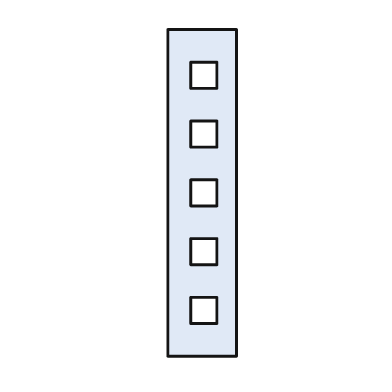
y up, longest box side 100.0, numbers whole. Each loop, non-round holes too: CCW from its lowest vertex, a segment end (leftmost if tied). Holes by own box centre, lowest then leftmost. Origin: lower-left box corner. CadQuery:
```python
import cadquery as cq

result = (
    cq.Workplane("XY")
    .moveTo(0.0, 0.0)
    .lineTo(21.0, 0.0)
    .lineTo(21.0, 100.0)
    .lineTo(0.0, 100.0)
    .close()
    .moveTo(7.0, 10.0)
    .lineTo(15.0, 10.0)
    .lineTo(15.0, 18.0)
    .lineTo(7.0, 18.0)
    .close()
    .moveTo(7.0, 28.0)
    .lineTo(15.0, 28.0)
    .lineTo(15.0, 36.0)
    .lineTo(7.0, 36.0)
    .close()
    .moveTo(7.0, 46.0)
    .lineTo(15.0, 46.0)
    .lineTo(15.0, 54.0)
    .lineTo(7.0, 54.0)
    .close()
    .moveTo(7.0, 64.0)
    .lineTo(15.0, 64.0)
    .lineTo(15.0, 72.0)
    .lineTo(7.0, 72.0)
    .close()
    .moveTo(7.0, 82.0)
    .lineTo(15.0, 82.0)
    .lineTo(15.0, 90.0)
    .lineTo(7.0, 90.0)
    .close()
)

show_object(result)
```